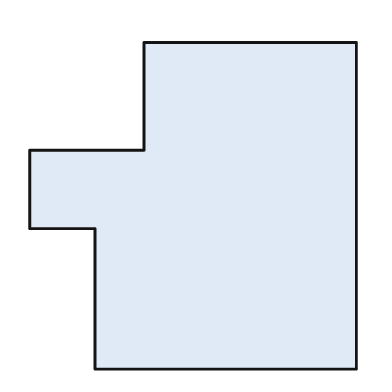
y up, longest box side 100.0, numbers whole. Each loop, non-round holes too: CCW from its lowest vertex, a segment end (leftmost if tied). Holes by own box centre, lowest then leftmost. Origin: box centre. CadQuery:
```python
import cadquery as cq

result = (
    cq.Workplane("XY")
    .moveTo(-30.0, -50.0)
    .lineTo(50.0, -50.0)
    .lineTo(50.0, 50.0)
    .lineTo(-15.0, 50.0)
    .lineTo(-15.0, 17.0)
    .lineTo(-50.0, 17.0)
    .lineTo(-50.0, -7.0)
    .lineTo(-30.0, -7.0)
    .close()
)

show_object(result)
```